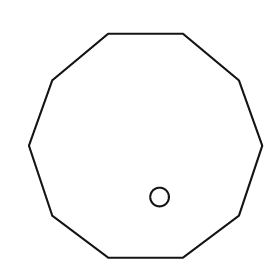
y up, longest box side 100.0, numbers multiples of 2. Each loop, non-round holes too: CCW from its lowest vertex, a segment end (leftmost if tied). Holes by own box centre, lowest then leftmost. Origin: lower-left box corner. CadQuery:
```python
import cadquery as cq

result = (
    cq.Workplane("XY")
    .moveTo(34.0, 0.0)
    .lineTo(66.0, 0.0)
    .lineTo(90.0, 18.0)
    .lineTo(100.0, 48.0)
    .lineTo(90.0, 76.0)
    .lineTo(66.0, 96.0)
    .lineTo(34.0, 96.0)
    .lineTo(10.0, 76.0)
    .lineTo(0.0, 48.0)
    .lineTo(10.0, 18.0)
    .close()
    .moveTo(56.0, 26.0)
    .circle(4.0)
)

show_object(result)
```